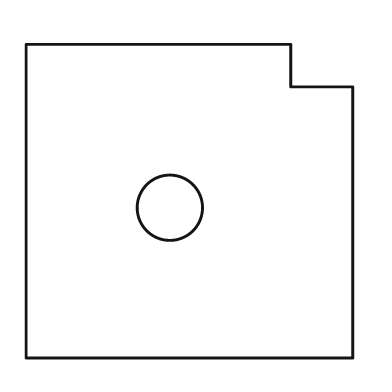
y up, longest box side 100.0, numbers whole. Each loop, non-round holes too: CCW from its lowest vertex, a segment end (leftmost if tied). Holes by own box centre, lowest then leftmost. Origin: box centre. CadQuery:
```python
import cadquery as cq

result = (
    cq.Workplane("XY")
    .moveTo(-50.0, -48.0)
    .lineTo(50.0, -48.0)
    .lineTo(50.0, 35.0)
    .lineTo(31.0, 35.0)
    .lineTo(31.0, 48.0)
    .lineTo(-50.0, 48.0)
    .close()
    .moveTo(-6.0, -2.0)
    .circle(10.0)
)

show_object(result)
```